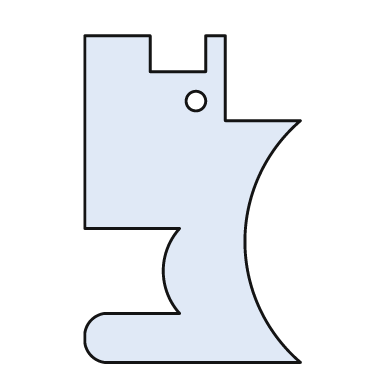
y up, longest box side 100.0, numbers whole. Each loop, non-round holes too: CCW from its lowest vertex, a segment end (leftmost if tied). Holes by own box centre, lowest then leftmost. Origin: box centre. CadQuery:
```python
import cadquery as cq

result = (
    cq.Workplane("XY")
    .moveTo(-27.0, -50.0)
    .lineTo(33.0, -50.0)
    .threePointArc((16.0, -13.0), (33.0, 24.0))
    .lineTo(10.0, 24.0)
    .lineTo(10.0, 50.0)
    .lineTo(4.0, 50.0)
    .lineTo(4.0, 39.0)
    .lineTo(-13.0, 39.0)
    .lineTo(-13.0, 50.0)
    .lineTo(-33.0, 50.0)
    .lineTo(-33.0, -9.0)
    .lineTo(-4.0, -9.0)
    .threePointArc((-9.0, -22.0), (-4.0, -35.0))
    .lineTo(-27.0, -35.0)
    .threePointArc((-31.0, -37.0), (-33.0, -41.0))
    .lineTo(-33.0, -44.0)
    .threePointArc((-31.0, -48.0), (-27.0, -50.0))
    .close()
    .moveTo(1.0, 30.0)
    .circle(3.0)
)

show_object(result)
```